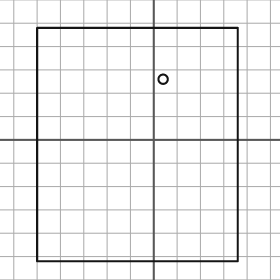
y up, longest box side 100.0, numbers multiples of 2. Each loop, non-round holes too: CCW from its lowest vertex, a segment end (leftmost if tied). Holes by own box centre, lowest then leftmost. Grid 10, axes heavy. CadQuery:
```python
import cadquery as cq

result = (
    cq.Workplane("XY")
    .moveTo(-50.0, -52.0)
    .lineTo(36.0, -52.0)
    .lineTo(36.0, 48.0)
    .lineTo(-50.0, 48.0)
    .close()
    .moveTo(4.0, 26.0)
    .circle(2.0)
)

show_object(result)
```